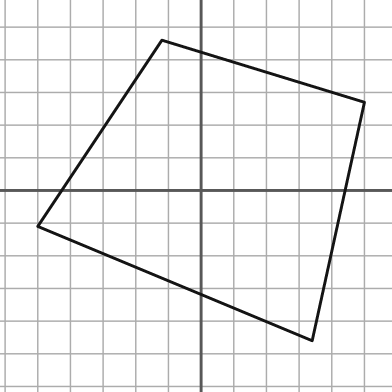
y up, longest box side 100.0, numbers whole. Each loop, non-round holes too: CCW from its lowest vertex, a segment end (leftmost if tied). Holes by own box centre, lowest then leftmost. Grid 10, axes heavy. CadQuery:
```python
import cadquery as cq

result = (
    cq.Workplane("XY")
    .moveTo(34.0, -46.0)
    .lineTo(50.0, 27.0)
    .lineTo(-12.0, 46.0)
    .lineTo(-50.0, -11.0)
    .close()
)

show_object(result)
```